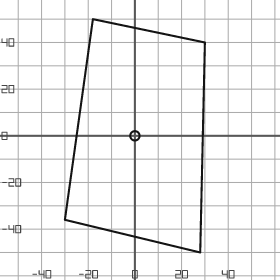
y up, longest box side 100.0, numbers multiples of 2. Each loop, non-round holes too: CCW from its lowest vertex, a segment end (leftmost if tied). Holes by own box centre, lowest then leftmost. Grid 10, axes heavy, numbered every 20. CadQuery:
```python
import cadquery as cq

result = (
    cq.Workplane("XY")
    .moveTo(28.0, -50.0)
    .lineTo(30.0, 40.0)
    .lineTo(-18.0, 50.0)
    .lineTo(-30.0, -36.0)
    .close()
    .moveTo(0.0, 0.0)
    .circle(2.0)
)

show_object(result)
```